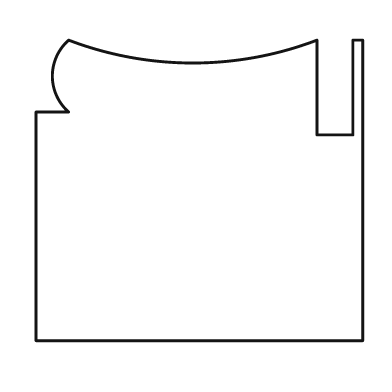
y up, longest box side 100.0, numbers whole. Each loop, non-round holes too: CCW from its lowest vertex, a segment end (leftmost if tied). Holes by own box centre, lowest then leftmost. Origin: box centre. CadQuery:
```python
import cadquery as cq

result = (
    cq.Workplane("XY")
    .moveTo(-50.0, -46.0)
    .lineTo(50.0, -46.0)
    .lineTo(50.0, 46.0)
    .lineTo(47.0, 46.0)
    .lineTo(47.0, 17.0)
    .lineTo(36.0, 17.0)
    .lineTo(36.0, 46.0)
    .threePointArc((-2.0, 39.0), (-40.0, 46.0))
    .threePointArc((-45.0, 35.0), (-40.0, 24.0))
    .lineTo(-50.0, 24.0)
    .close()
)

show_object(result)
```